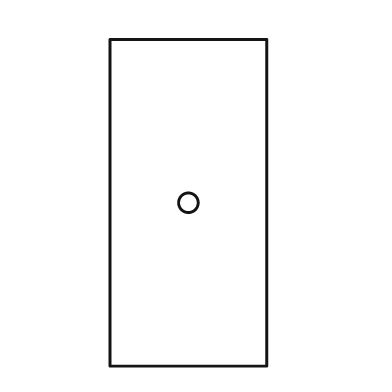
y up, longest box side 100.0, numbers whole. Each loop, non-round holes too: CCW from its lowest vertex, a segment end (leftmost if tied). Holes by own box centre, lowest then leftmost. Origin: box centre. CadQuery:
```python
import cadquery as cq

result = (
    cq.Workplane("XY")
    .moveTo(-24.0, -50.0)
    .lineTo(24.0, -50.0)
    .lineTo(24.0, 50.0)
    .lineTo(-24.0, 50.0)
    .close()
    .moveTo(0.0, 0.0)
    .circle(3.0)
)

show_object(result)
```